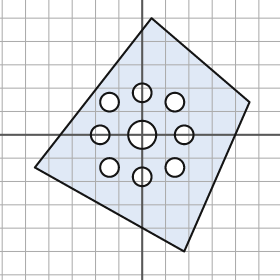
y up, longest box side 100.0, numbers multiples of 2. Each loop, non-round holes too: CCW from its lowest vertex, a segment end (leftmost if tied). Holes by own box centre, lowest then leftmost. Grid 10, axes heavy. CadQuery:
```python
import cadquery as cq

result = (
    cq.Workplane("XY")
    .moveTo(18.0, -50.0)
    .lineTo(46.0, 14.0)
    .lineTo(4.0, 50.0)
    .lineTo(-46.0, -14.0)
    .close()
    .moveTo(0.0, -18.0)
    .circle(4.0)
    .moveTo(-14.0, -14.0)
    .circle(4.0)
    .moveTo(14.0, -14.0)
    .circle(4.0)
    .moveTo(-18.0, 0.0)
    .circle(4.0)
    .moveTo(0.0, 0.0)
    .circle(6.0)
    .moveTo(18.0, 0.0)
    .circle(4.0)
    .moveTo(-14.0, 14.0)
    .circle(4.0)
    .moveTo(14.0, 14.0)
    .circle(4.0)
    .moveTo(0.0, 18.0)
    .circle(4.0)
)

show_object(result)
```